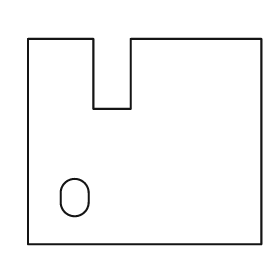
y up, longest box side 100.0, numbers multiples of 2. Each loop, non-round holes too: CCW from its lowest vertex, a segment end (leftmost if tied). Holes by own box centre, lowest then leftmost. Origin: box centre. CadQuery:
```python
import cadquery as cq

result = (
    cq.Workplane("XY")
    .moveTo(-50.0, -44.0)
    .lineTo(50.0, -44.0)
    .lineTo(50.0, 44.0)
    .lineTo(-6.0, 44.0)
    .lineTo(-6.0, 14.0)
    .lineTo(-22.0, 14.0)
    .lineTo(-22.0, 44.0)
    .lineTo(-50.0, 44.0)
    .close()
    .moveTo(-36.0, -26.0)
    .threePointArc((-30.0, -32.0), (-24.0, -26.0))
    .lineTo(-24.0, -22.0)
    .threePointArc((-30.0, -16.0), (-36.0, -22.0))
    .close()
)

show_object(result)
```